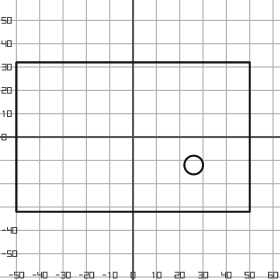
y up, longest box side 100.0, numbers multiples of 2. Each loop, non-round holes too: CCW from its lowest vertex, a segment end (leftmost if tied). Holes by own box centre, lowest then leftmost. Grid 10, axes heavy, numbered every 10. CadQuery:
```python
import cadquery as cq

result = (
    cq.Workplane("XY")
    .moveTo(-50.0, -32.0)
    .lineTo(50.0, -32.0)
    .lineTo(50.0, 32.0)
    .lineTo(-50.0, 32.0)
    .close()
    .moveTo(26.0, -12.0)
    .circle(4.0)
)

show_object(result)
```